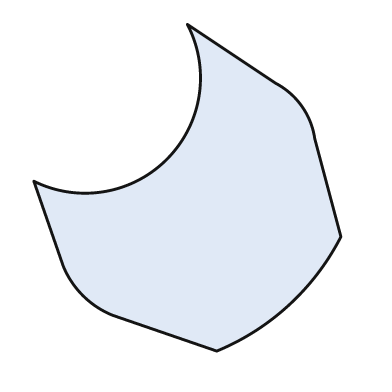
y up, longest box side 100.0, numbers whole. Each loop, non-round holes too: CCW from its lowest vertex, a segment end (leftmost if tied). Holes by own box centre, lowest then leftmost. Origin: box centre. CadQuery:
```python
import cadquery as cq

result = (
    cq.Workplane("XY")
    .moveTo(9.0, -50.0)
    .threePointArc((31.0, -36.0), (47.0, -15.0))
    .lineTo(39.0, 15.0)
    .threePointArc((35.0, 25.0), (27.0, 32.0))
    .lineTo(0.0, 50.0)
    .threePointArc((-6.0, 9.0), (-47.0, 2.0))
    .lineTo(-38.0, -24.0)
    .threePointArc((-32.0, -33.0), (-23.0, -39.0))
    .close()
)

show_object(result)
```